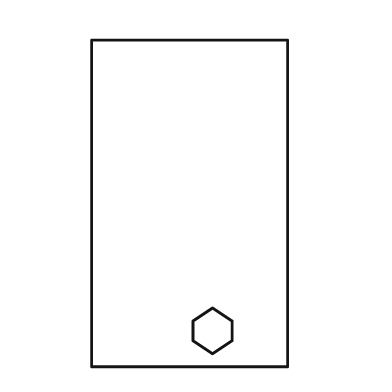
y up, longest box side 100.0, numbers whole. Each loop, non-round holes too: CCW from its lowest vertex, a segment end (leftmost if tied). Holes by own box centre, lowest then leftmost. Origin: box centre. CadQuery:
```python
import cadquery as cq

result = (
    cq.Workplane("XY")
    .moveTo(-30.0, -50.0)
    .lineTo(30.0, -50.0)
    .lineTo(30.0, 50.0)
    .lineTo(-30.0, 50.0)
    .close()
    .moveTo(7.0, -46.0)
    .lineTo(13.0, -42.0)
    .lineTo(13.0, -36.0)
    .lineTo(7.0, -32.0)
    .lineTo(1.0, -36.0)
    .lineTo(1.0, -42.0)
    .close()
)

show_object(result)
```